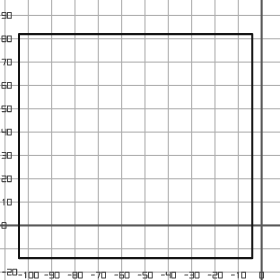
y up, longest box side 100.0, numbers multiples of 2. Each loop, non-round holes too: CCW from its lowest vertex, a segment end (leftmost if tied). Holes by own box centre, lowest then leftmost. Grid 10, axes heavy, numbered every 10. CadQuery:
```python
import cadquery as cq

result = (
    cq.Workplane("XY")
    .moveTo(-104.0, -14.0)
    .lineTo(-4.0, -14.0)
    .lineTo(-4.0, 82.0)
    .lineTo(-104.0, 82.0)
    .close()
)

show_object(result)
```